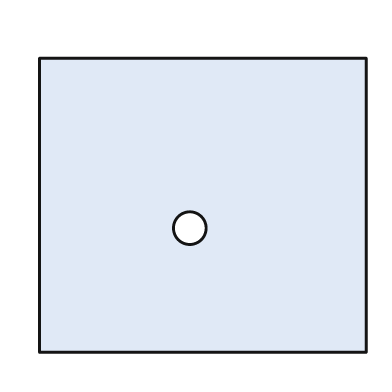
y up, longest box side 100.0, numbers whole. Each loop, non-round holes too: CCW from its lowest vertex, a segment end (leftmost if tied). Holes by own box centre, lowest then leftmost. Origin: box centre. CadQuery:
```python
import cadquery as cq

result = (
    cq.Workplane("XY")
    .moveTo(-50.0, -45.0)
    .lineTo(50.0, -45.0)
    .lineTo(50.0, 45.0)
    .lineTo(-50.0, 45.0)
    .close()
    .moveTo(-4.0, -7.0)
    .circle(5.0)
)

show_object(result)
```